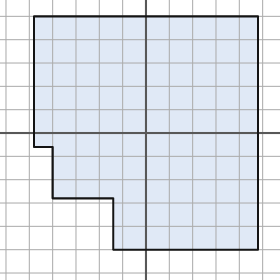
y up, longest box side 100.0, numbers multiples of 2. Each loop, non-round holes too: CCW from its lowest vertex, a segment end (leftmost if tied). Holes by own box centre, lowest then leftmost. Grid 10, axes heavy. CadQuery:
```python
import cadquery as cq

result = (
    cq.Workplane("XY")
    .moveTo(-14.0, -50.0)
    .lineTo(48.0, -50.0)
    .lineTo(48.0, 50.0)
    .lineTo(-48.0, 50.0)
    .lineTo(-48.0, -6.0)
    .lineTo(-40.0, -6.0)
    .lineTo(-40.0, -28.0)
    .lineTo(-14.0, -28.0)
    .close()
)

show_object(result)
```